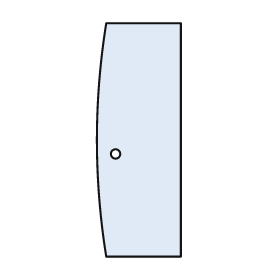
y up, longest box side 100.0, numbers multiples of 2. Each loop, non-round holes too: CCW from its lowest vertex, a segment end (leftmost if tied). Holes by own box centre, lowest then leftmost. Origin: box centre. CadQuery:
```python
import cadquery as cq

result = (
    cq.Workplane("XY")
    .moveTo(-14.0, -50.0)
    .lineTo(18.0, -50.0)
    .lineTo(18.0, 50.0)
    .lineTo(-14.0, 50.0)
    .threePointArc((-18.0, 0.0), (-14.0, -50.0))
    .close()
    .moveTo(-10.0, -6.0)
    .circle(2.0)
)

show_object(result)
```